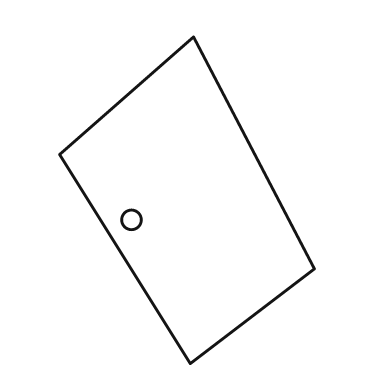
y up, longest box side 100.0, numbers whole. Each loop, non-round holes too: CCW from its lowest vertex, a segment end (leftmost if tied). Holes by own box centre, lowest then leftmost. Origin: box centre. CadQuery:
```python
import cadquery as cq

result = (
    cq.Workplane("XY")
    .moveTo(1.0, -50.0)
    .lineTo(39.0, -21.0)
    .lineTo(2.0, 50.0)
    .lineTo(-39.0, 14.0)
    .close()
    .moveTo(-17.0, -6.0)
    .circle(3.0)
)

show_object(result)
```